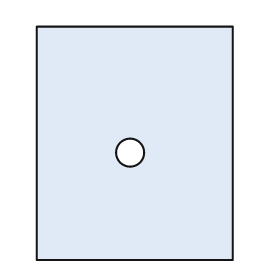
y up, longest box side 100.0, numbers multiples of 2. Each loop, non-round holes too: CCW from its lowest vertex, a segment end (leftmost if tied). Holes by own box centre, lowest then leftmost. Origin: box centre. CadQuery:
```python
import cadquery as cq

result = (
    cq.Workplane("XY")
    .moveTo(-42.0, -50.0)
    .lineTo(42.0, -50.0)
    .lineTo(42.0, 50.0)
    .lineTo(-42.0, 50.0)
    .close()
    .moveTo(-2.0, -4.0)
    .circle(6.0)
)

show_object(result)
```